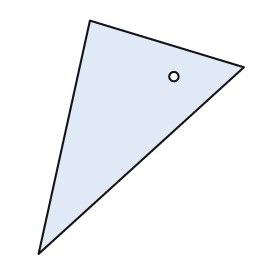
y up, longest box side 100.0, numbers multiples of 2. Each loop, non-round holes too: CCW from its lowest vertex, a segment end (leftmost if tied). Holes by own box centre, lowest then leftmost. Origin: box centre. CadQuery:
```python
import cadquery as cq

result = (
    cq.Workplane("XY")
    .moveTo(-44.0, -50.0)
    .lineTo(44.0, 30.0)
    .lineTo(-22.0, 50.0)
    .close()
    .moveTo(14.0, 26.0)
    .circle(2.0)
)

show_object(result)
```